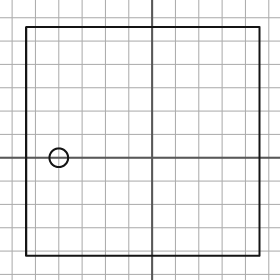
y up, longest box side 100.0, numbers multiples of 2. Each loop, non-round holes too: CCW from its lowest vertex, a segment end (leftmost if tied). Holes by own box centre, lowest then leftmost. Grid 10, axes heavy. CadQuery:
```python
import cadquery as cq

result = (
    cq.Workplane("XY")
    .moveTo(-54.0, -42.0)
    .lineTo(46.0, -42.0)
    .lineTo(46.0, 56.0)
    .lineTo(-54.0, 56.0)
    .close()
    .moveTo(-40.0, 0.0)
    .circle(4.0)
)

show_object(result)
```